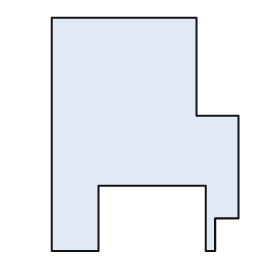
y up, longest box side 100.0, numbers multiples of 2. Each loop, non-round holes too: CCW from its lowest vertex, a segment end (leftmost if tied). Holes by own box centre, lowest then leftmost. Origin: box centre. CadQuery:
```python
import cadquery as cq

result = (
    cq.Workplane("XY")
    .moveTo(-40.0, -50.0)
    .lineTo(-20.0, -50.0)
    .lineTo(-20.0, -22.0)
    .lineTo(26.0, -22.0)
    .lineTo(26.0, -50.0)
    .lineTo(30.0, -50.0)
    .lineTo(30.0, -36.0)
    .lineTo(40.0, -36.0)
    .lineTo(40.0, 8.0)
    .lineTo(22.0, 8.0)
    .lineTo(22.0, 50.0)
    .lineTo(-40.0, 50.0)
    .close()
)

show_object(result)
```